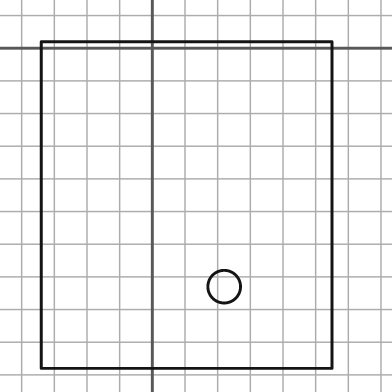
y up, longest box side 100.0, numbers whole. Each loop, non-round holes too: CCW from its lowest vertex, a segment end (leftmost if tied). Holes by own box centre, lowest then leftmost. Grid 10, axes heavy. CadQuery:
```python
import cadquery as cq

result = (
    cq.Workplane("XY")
    .moveTo(-34.0, -98.0)
    .lineTo(55.0, -98.0)
    .lineTo(55.0, 2.0)
    .lineTo(-34.0, 2.0)
    .close()
    .moveTo(22.0, -73.0)
    .circle(5.0)
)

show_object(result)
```